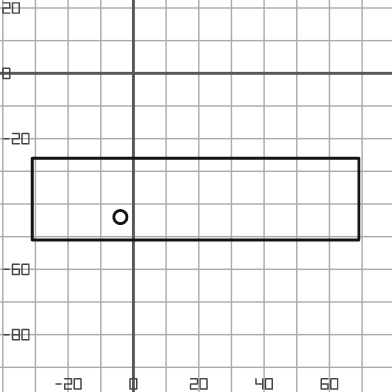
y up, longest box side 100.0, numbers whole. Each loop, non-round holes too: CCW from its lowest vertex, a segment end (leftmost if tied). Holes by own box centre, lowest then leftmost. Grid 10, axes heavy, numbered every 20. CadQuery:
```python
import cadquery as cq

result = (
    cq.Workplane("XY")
    .moveTo(-31.0, -51.0)
    .lineTo(69.0, -51.0)
    .lineTo(69.0, -26.0)
    .lineTo(-31.0, -26.0)
    .close()
    .moveTo(-4.0, -44.0)
    .circle(2.0)
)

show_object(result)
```